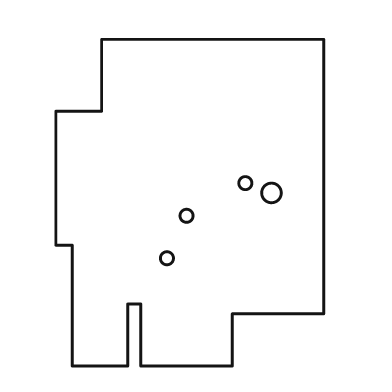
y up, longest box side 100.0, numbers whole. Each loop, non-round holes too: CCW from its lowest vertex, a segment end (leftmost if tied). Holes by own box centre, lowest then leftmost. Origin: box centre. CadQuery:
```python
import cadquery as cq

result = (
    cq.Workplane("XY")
    .moveTo(-36.0, -50.0)
    .lineTo(-19.0, -50.0)
    .lineTo(-19.0, -31.0)
    .lineTo(-15.0, -31.0)
    .lineTo(-15.0, -50.0)
    .lineTo(13.0, -50.0)
    .lineTo(13.0, -34.0)
    .lineTo(41.0, -34.0)
    .lineTo(41.0, 50.0)
    .lineTo(-27.0, 50.0)
    .lineTo(-27.0, 28.0)
    .lineTo(-41.0, 28.0)
    .lineTo(-41.0, -13.0)
    .lineTo(-36.0, -13.0)
    .close()
    .moveTo(-7.0, -17.0)
    .circle(2.0)
    .moveTo(-1.0, -4.0)
    .circle(2.0)
    .moveTo(25.0, 3.0)
    .circle(3.0)
    .moveTo(17.0, 6.0)
    .circle(2.0)
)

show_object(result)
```